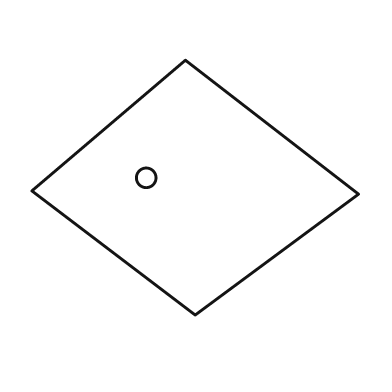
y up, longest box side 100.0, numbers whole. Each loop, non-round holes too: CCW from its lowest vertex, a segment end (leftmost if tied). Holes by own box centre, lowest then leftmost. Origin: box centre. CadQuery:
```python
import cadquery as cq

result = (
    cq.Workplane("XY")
    .moveTo(0.0, -39.0)
    .lineTo(50.0, -2.0)
    .lineTo(-3.0, 39.0)
    .lineTo(-50.0, -1.0)
    .close()
    .moveTo(-15.0, 3.0)
    .circle(3.0)
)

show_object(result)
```